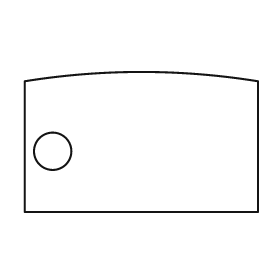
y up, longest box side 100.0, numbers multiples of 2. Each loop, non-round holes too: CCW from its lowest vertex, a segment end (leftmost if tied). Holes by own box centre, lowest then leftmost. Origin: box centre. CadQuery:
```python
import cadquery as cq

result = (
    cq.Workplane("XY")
    .moveTo(-50.0, -30.0)
    .lineTo(50.0, -30.0)
    .lineTo(50.0, 26.0)
    .threePointArc((0.0, 30.0), (-50.0, 26.0))
    .close()
    .moveTo(-38.0, -4.0)
    .circle(8.0)
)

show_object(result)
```